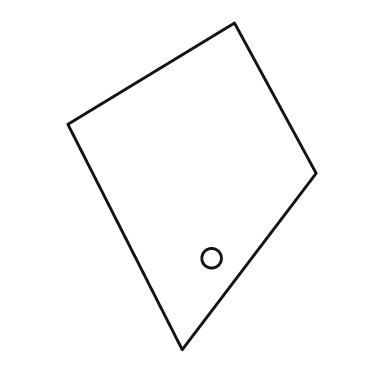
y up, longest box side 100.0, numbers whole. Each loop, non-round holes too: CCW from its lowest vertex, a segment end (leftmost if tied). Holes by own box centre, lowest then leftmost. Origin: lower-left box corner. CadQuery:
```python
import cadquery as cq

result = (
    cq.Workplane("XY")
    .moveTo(35.0, 0.0)
    .lineTo(76.0, 54.0)
    .lineTo(51.0, 100.0)
    .lineTo(0.0, 69.0)
    .close()
    .moveTo(44.0, 28.0)
    .circle(3.0)
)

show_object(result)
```